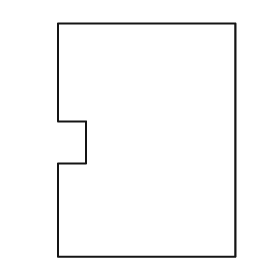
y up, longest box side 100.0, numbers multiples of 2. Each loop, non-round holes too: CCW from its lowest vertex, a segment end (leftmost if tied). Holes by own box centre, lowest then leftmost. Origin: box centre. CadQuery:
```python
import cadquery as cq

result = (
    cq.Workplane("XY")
    .moveTo(-38.0, -50.0)
    .lineTo(38.0, -50.0)
    .lineTo(38.0, 50.0)
    .lineTo(-38.0, 50.0)
    .lineTo(-38.0, 8.0)
    .lineTo(-26.0, 8.0)
    .lineTo(-26.0, -10.0)
    .lineTo(-38.0, -10.0)
    .close()
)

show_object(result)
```